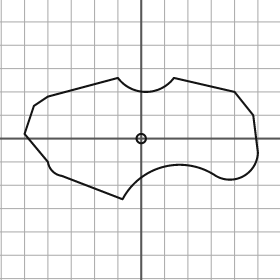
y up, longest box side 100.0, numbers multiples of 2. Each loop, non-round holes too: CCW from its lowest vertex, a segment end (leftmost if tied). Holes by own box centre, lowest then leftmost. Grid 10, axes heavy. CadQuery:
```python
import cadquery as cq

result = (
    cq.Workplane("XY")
    .moveTo(-8.0, -26.0)
    .threePointArc((10.0, -12.0), (32.0, -16.0))
    .threePointArc((44.0, -16.0), (50.0, -6.0))
    .lineTo(48.0, 10.0)
    .lineTo(40.0, 20.0)
    .lineTo(14.0, 26.0)
    .threePointArc((2.0, 20.0), (-10.0, 26.0))
    .lineTo(-40.0, 18.0)
    .lineTo(-46.0, 14.0)
    .lineTo(-50.0, 2.0)
    .lineTo(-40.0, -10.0)
    .threePointArc((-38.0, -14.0), (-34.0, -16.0))
    .close()
    .moveTo(0.0, 0.0)
    .circle(2.0)
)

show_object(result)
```